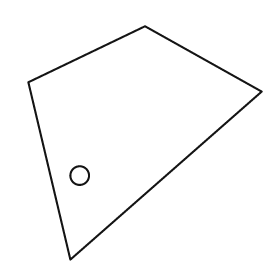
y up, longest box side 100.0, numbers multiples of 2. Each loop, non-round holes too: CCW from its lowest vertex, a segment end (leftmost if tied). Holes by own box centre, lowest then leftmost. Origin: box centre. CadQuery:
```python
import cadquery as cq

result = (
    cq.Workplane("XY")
    .moveTo(-32.0, -50.0)
    .lineTo(50.0, 22.0)
    .lineTo(0.0, 50.0)
    .lineTo(-50.0, 26.0)
    .close()
    .moveTo(-28.0, -14.0)
    .circle(4.0)
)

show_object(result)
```